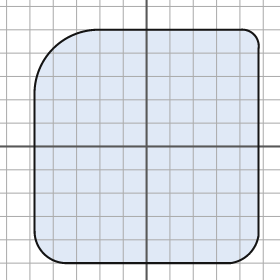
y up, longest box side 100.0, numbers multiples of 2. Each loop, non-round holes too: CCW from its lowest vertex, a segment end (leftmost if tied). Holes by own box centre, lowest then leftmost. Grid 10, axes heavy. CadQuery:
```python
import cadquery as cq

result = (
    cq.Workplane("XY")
    .moveTo(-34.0, -50.0)
    .lineTo(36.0, -50.0)
    .threePointArc((44.0, -46.0), (48.0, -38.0))
    .lineTo(48.0, 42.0)
    .threePointArc((46.0, 48.0), (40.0, 50.0))
    .lineTo(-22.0, 50.0)
    .threePointArc((-40.0, 42.0), (-48.0, 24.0))
    .lineTo(-48.0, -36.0)
    .threePointArc((-44.0, -46.0), (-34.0, -50.0))
    .close()
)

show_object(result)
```